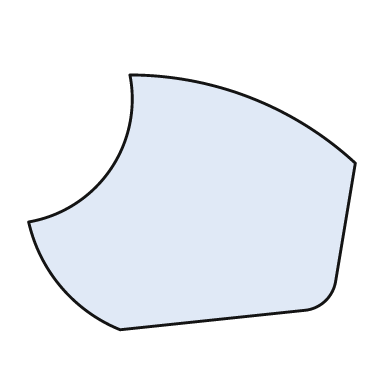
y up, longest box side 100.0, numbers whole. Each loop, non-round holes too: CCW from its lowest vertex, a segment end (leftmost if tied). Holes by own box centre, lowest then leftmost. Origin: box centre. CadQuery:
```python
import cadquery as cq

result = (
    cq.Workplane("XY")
    .moveTo(-22.0, -39.0)
    .lineTo(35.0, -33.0)
    .threePointArc((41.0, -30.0), (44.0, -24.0))
    .lineTo(50.0, 12.0)
    .threePointArc((18.0, 32.0), (-19.0, 39.0))
    .threePointArc((-25.0, 10.0), (-50.0, -6.0))
    .threePointArc((-40.0, -26.0), (-22.0, -39.0))
    .close()
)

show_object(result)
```